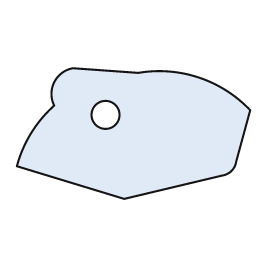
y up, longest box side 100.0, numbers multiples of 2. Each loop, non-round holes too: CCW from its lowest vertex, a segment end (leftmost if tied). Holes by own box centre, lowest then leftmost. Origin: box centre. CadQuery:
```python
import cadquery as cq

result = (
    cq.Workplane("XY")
    .moveTo(-4.0, -28.0)
    .lineTo(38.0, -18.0)
    .threePointArc((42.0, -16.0), (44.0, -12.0))
    .lineTo(50.0, 10.0)
    .threePointArc((28.0, 24.0), (2.0, 26.0))
    .lineTo(-26.0, 28.0)
    .threePointArc((-34.0, 22.0), (-34.0, 12.0))
    .threePointArc((-44.0, 0.0), (-50.0, -14.0))
    .close()
    .moveTo(-12.0, 8.0)
    .circle(6.0)
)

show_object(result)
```